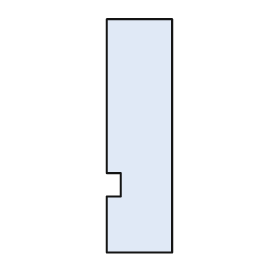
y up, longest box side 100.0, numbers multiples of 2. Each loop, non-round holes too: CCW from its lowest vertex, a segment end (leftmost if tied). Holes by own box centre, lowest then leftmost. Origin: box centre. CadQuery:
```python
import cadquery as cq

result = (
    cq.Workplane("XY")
    .moveTo(-14.0, -50.0)
    .lineTo(14.0, -50.0)
    .lineTo(14.0, 50.0)
    .lineTo(-14.0, 50.0)
    .lineTo(-14.0, -16.0)
    .lineTo(-8.0, -16.0)
    .lineTo(-8.0, -26.0)
    .lineTo(-14.0, -26.0)
    .close()
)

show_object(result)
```